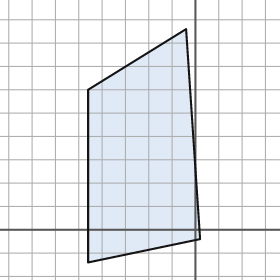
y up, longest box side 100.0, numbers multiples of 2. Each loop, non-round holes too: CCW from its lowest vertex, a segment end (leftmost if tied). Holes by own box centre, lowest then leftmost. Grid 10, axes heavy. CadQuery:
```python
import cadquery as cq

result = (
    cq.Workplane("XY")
    .moveTo(-46.0, -14.0)
    .lineTo(2.0, -4.0)
    .lineTo(-4.0, 86.0)
    .lineTo(-46.0, 60.0)
    .close()
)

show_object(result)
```